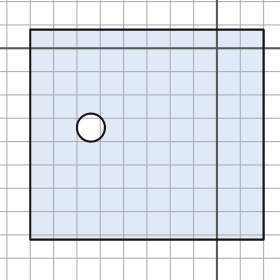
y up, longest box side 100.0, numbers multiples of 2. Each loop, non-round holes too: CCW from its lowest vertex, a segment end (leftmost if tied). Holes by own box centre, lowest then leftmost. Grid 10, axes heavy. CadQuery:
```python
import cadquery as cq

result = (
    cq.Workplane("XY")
    .moveTo(-80.0, -82.0)
    .lineTo(20.0, -82.0)
    .lineTo(20.0, 8.0)
    .lineTo(-80.0, 8.0)
    .close()
    .moveTo(-54.0, -34.0)
    .circle(6.0)
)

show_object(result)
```